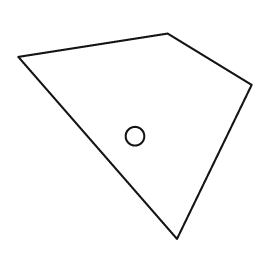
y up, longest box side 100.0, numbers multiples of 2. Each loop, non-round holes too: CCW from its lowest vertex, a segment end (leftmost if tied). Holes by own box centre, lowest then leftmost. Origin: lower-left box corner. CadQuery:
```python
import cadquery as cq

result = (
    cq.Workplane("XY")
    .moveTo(68.0, 0.0)
    .lineTo(100.0, 66.0)
    .lineTo(64.0, 88.0)
    .lineTo(0.0, 78.0)
    .close()
    .moveTo(50.0, 44.0)
    .circle(4.0)
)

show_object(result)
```